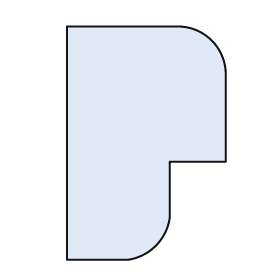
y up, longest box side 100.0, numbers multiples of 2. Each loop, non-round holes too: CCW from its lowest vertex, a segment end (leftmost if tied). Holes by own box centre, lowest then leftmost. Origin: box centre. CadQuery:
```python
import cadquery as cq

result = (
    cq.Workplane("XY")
    .moveTo(-34.0, -50.0)
    .lineTo(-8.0, -50.0)
    .threePointArc((4.0, -44.0), (10.0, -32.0))
    .lineTo(10.0, -8.0)
    .lineTo(34.0, -8.0)
    .lineTo(34.0, 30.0)
    .threePointArc((28.0, 44.0), (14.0, 50.0))
    .lineTo(-34.0, 50.0)
    .close()
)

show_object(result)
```